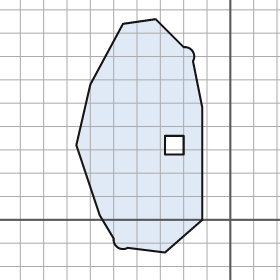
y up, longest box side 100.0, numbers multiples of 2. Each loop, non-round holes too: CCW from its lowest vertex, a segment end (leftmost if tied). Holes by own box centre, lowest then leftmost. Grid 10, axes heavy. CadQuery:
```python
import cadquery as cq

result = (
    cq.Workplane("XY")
    .moveTo(-28.0, -14.0)
    .lineTo(-12.0, 0.0)
    .lineTo(-12.0, 48.0)
    .lineTo(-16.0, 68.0)
    .threePointArc((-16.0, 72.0), (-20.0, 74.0))
    .lineTo(-32.0, 86.0)
    .lineTo(-46.0, 84.0)
    .lineTo(-60.0, 58.0)
    .lineTo(-66.0, 32.0)
    .lineTo(-56.0, 2.0)
    .lineTo(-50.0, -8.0)
    .threePointArc((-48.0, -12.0), (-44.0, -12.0))
    .close()
    .moveTo(-28.0, 28.0)
    .lineTo(-20.0, 28.0)
    .lineTo(-20.0, 36.0)
    .lineTo(-28.0, 36.0)
    .close()
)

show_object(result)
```